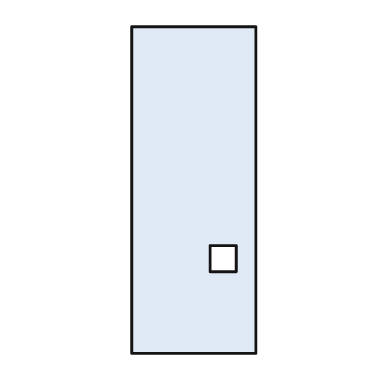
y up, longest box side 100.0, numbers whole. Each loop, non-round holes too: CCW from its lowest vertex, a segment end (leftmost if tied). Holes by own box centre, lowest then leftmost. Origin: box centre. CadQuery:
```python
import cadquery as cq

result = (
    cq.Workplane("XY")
    .moveTo(-19.0, -50.0)
    .lineTo(19.0, -50.0)
    .lineTo(19.0, 50.0)
    .lineTo(-19.0, 50.0)
    .close()
    .moveTo(5.0, -25.0)
    .lineTo(13.0, -25.0)
    .lineTo(13.0, -17.0)
    .lineTo(5.0, -17.0)
    .close()
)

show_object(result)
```